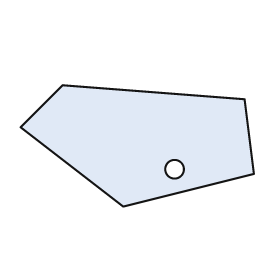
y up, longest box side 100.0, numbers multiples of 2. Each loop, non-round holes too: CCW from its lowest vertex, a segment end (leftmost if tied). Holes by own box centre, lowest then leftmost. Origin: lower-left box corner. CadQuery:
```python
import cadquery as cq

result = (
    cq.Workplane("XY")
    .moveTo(44.0, 0.0)
    .lineTo(100.0, 14.0)
    .lineTo(96.0, 46.0)
    .lineTo(18.0, 52.0)
    .lineTo(0.0, 34.0)
    .close()
    .moveTo(66.0, 16.0)
    .circle(4.0)
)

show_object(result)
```